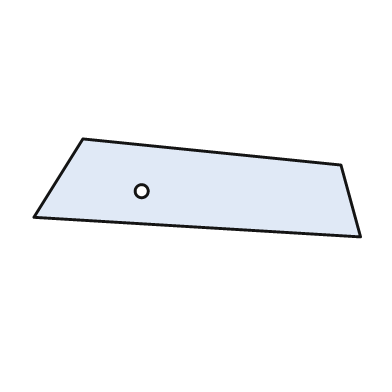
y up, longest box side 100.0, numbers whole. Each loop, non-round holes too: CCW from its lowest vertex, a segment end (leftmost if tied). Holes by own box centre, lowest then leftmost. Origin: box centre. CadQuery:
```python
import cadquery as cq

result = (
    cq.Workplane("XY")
    .moveTo(50.0, -15.0)
    .lineTo(44.0, 7.0)
    .lineTo(-35.0, 15.0)
    .lineTo(-50.0, -9.0)
    .close()
    .moveTo(-17.0, -1.0)
    .circle(2.0)
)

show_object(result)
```